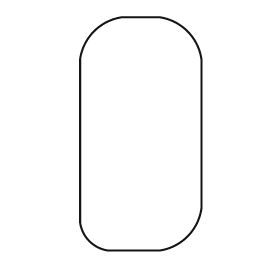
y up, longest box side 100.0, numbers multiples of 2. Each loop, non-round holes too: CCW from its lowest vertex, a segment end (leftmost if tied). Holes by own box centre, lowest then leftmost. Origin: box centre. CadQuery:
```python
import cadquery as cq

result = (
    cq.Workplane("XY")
    .moveTo(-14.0, -50.0)
    .lineTo(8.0, -50.0)
    .threePointArc((20.0, -44.0), (26.0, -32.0))
    .lineTo(26.0, 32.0)
    .threePointArc((20.0, 44.0), (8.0, 50.0))
    .lineTo(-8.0, 50.0)
    .threePointArc((-20.0, 44.0), (-26.0, 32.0))
    .lineTo(-26.0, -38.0)
    .threePointArc((-22.0, -46.0), (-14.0, -50.0))
    .close()
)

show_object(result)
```